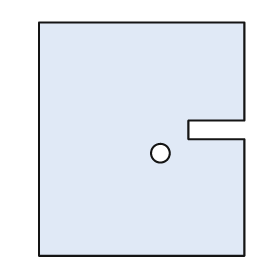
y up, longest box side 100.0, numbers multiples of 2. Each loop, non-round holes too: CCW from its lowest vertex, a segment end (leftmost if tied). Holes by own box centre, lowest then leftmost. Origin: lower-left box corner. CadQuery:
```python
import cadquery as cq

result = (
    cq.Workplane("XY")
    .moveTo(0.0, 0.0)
    .lineTo(88.0, 0.0)
    .lineTo(88.0, 50.0)
    .lineTo(64.0, 50.0)
    .lineTo(64.0, 58.0)
    .lineTo(88.0, 58.0)
    .lineTo(88.0, 100.0)
    .lineTo(0.0, 100.0)
    .close()
    .moveTo(52.0, 44.0)
    .circle(4.0)
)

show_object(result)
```